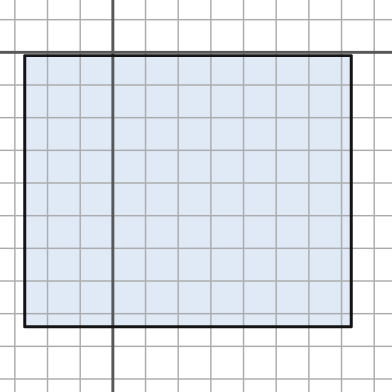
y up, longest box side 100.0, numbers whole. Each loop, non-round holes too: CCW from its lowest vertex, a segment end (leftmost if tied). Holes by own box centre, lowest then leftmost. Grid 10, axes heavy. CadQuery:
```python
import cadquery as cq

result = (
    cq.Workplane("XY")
    .moveTo(-27.0, -84.0)
    .lineTo(73.0, -84.0)
    .lineTo(73.0, -1.0)
    .lineTo(-27.0, -1.0)
    .close()
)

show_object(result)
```